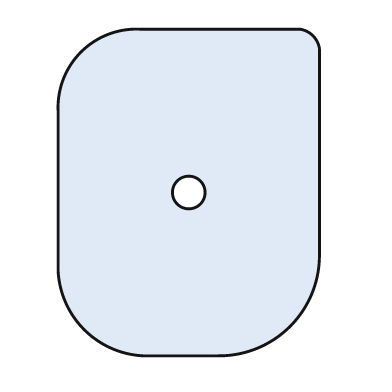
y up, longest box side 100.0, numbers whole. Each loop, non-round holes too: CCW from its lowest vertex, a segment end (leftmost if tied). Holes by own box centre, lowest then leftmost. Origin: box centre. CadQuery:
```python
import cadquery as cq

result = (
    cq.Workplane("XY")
    .moveTo(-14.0, -50.0)
    .lineTo(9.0, -50.0)
    .threePointArc((31.0, -41.0), (40.0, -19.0))
    .lineTo(40.0, 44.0)
    .threePointArc((38.0, 48.0), (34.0, 50.0))
    .lineTo(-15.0, 50.0)
    .threePointArc((-33.0, 43.0), (-40.0, 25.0))
    .lineTo(-40.0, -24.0)
    .threePointArc((-32.0, -42.0), (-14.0, -50.0))
    .close()
    .moveTo(0.0, 0.0)
    .circle(5.0)
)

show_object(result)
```